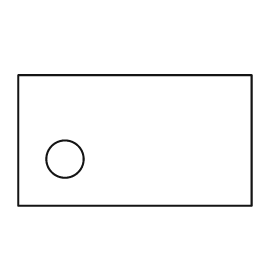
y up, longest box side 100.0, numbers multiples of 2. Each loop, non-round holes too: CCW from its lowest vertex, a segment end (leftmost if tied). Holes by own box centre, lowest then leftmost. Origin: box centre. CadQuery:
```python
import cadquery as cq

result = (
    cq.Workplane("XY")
    .moveTo(-50.0, -28.0)
    .lineTo(50.0, -28.0)
    .lineTo(50.0, 28.0)
    .lineTo(-50.0, 28.0)
    .close()
    .moveTo(-30.0, -8.0)
    .circle(8.0)
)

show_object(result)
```